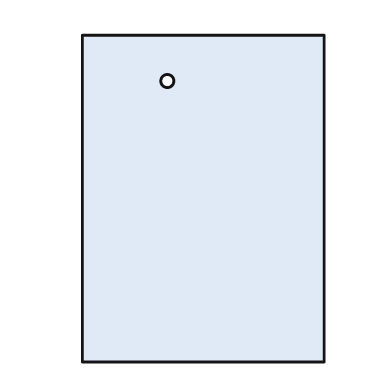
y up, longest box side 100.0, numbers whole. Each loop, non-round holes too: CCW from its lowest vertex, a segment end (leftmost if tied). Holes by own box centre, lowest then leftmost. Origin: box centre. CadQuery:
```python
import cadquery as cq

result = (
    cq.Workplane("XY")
    .moveTo(-37.0, -50.0)
    .lineTo(37.0, -50.0)
    .lineTo(37.0, 50.0)
    .lineTo(-37.0, 50.0)
    .close()
    .moveTo(-11.0, 36.0)
    .circle(2.0)
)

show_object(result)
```